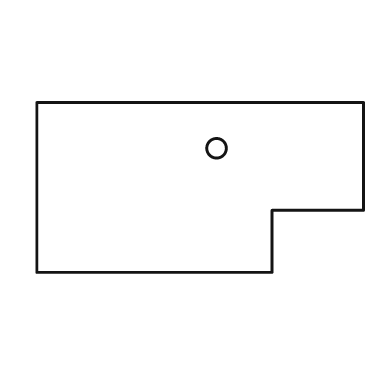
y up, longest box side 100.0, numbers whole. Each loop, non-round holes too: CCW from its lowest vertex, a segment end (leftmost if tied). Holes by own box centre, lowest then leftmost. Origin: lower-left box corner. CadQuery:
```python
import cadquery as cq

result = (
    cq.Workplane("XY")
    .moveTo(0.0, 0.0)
    .lineTo(72.0, 0.0)
    .lineTo(72.0, 19.0)
    .lineTo(100.0, 19.0)
    .lineTo(100.0, 52.0)
    .lineTo(0.0, 52.0)
    .close()
    .moveTo(55.0, 38.0)
    .circle(3.0)
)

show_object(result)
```